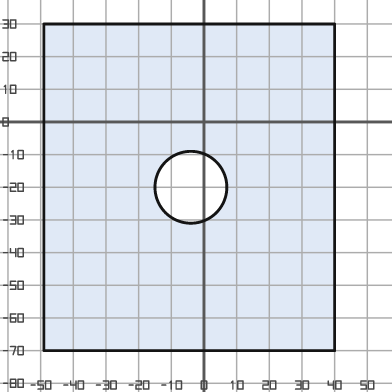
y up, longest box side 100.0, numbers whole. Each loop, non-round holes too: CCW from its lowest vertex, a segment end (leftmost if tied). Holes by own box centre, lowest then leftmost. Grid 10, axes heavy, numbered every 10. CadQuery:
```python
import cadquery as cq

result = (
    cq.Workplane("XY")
    .moveTo(-49.0, -70.0)
    .lineTo(40.0, -70.0)
    .lineTo(40.0, 30.0)
    .lineTo(-49.0, 30.0)
    .close()
    .moveTo(-4.0, -20.0)
    .circle(11.0)
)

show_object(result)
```